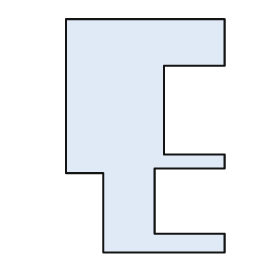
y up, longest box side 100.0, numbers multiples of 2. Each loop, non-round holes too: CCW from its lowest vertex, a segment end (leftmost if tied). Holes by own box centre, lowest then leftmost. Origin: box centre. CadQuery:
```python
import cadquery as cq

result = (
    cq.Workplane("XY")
    .moveTo(-18.0, -50.0)
    .lineTo(34.0, -50.0)
    .lineTo(34.0, -42.0)
    .lineTo(4.0, -42.0)
    .lineTo(4.0, -14.0)
    .lineTo(34.0, -14.0)
    .lineTo(34.0, -8.0)
    .lineTo(8.0, -8.0)
    .lineTo(8.0, 30.0)
    .lineTo(34.0, 30.0)
    .lineTo(34.0, 50.0)
    .lineTo(-34.0, 50.0)
    .lineTo(-34.0, -16.0)
    .lineTo(-18.0, -16.0)
    .close()
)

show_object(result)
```